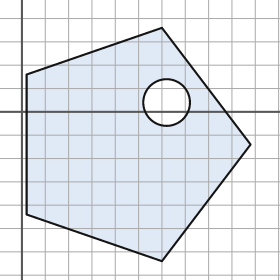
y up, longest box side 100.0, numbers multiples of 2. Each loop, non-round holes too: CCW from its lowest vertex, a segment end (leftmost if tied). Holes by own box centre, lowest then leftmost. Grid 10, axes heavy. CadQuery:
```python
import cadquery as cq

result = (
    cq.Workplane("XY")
    .moveTo(60.0, -64.0)
    .lineTo(98.0, -14.0)
    .lineTo(60.0, 36.0)
    .lineTo(2.0, 16.0)
    .lineTo(2.0, -44.0)
    .close()
    .moveTo(62.0, 4.0)
    .circle(10.0)
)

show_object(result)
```